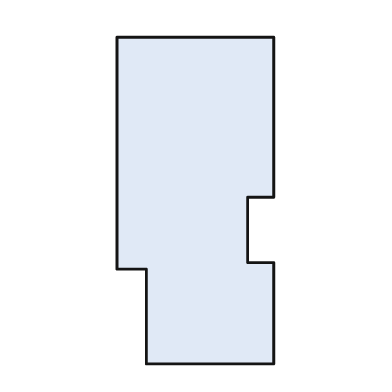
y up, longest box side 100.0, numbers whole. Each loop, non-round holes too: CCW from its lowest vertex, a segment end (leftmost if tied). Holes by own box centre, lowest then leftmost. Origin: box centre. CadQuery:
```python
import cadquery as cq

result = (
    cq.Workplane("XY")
    .moveTo(-15.0, -50.0)
    .lineTo(24.0, -50.0)
    .lineTo(24.0, -19.0)
    .lineTo(16.0, -19.0)
    .lineTo(16.0, 1.0)
    .lineTo(24.0, 1.0)
    .lineTo(24.0, 50.0)
    .lineTo(-24.0, 50.0)
    .lineTo(-24.0, -21.0)
    .lineTo(-15.0, -21.0)
    .close()
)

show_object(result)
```